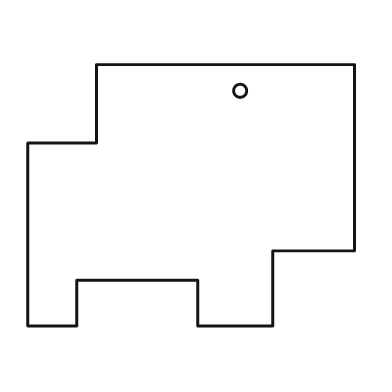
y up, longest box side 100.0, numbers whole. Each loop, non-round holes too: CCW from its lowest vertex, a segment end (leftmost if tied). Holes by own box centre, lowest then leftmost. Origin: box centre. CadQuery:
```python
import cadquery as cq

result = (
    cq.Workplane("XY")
    .moveTo(-50.0, -40.0)
    .lineTo(-35.0, -40.0)
    .lineTo(-35.0, -26.0)
    .lineTo(2.0, -26.0)
    .lineTo(2.0, -40.0)
    .lineTo(25.0, -40.0)
    .lineTo(25.0, -17.0)
    .lineTo(50.0, -17.0)
    .lineTo(50.0, 40.0)
    .lineTo(-29.0, 40.0)
    .lineTo(-29.0, 16.0)
    .lineTo(-50.0, 16.0)
    .close()
    .moveTo(15.0, 32.0)
    .circle(2.0)
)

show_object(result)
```